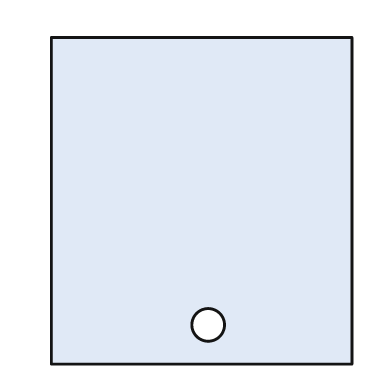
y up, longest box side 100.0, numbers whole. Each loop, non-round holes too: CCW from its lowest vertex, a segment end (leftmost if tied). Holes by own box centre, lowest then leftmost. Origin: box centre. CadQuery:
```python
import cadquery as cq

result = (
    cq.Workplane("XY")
    .moveTo(-46.0, -50.0)
    .lineTo(46.0, -50.0)
    .lineTo(46.0, 50.0)
    .lineTo(-46.0, 50.0)
    .close()
    .moveTo(2.0, -38.0)
    .circle(5.0)
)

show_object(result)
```